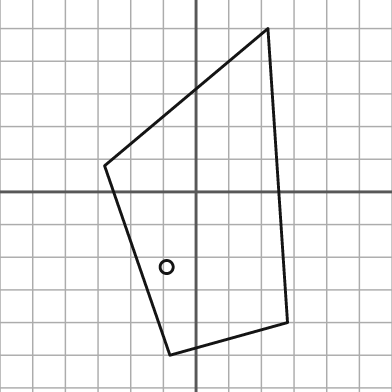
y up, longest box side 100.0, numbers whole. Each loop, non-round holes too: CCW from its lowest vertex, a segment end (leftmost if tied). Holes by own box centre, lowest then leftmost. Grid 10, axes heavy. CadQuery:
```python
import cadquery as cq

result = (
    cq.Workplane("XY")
    .moveTo(-8.0, -50.0)
    .lineTo(28.0, -40.0)
    .lineTo(22.0, 50.0)
    .lineTo(-28.0, 8.0)
    .close()
    .moveTo(-9.0, -23.0)
    .circle(2.0)
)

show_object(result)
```